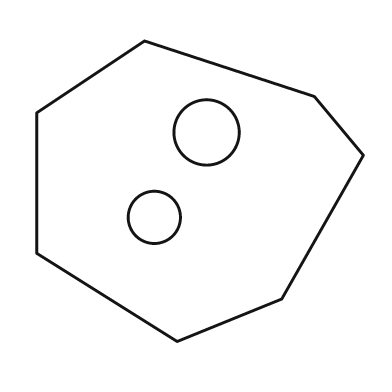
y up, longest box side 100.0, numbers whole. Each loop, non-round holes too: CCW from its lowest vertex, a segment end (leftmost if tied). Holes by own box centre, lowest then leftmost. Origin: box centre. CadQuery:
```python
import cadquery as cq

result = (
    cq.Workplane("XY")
    .moveTo(-7.0, -46.0)
    .lineTo(25.0, -33.0)
    .lineTo(50.0, 11.0)
    .lineTo(35.0, 29.0)
    .lineTo(-17.0, 46.0)
    .lineTo(-50.0, 24.0)
    .lineTo(-50.0, -19.0)
    .close()
    .moveTo(-14.0, -8.0)
    .circle(8.0)
    .moveTo(2.0, 18.0)
    .circle(10.0)
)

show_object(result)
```